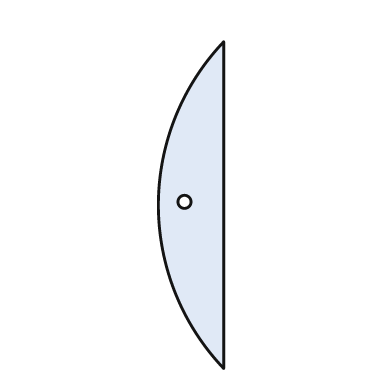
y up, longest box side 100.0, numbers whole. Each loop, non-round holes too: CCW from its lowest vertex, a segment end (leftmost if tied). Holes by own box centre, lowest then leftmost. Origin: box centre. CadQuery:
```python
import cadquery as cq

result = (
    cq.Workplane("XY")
    .moveTo(10.0, -50.0)
    .lineTo(10.0, 50.0)
    .threePointArc((-10.0, 0.0), (10.0, -50.0))
    .close()
    .moveTo(-2.0, 1.0)
    .circle(2.0)
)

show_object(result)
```